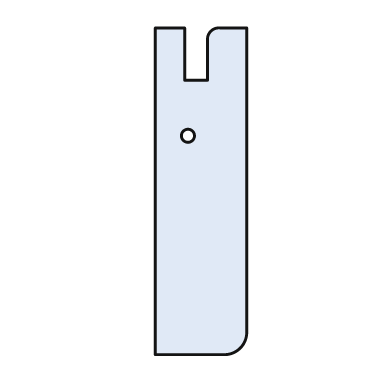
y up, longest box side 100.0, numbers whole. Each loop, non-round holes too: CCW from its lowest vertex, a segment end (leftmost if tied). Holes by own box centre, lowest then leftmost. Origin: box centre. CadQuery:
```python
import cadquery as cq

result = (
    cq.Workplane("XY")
    .moveTo(-14.0, -50.0)
    .lineTo(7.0, -50.0)
    .threePointArc((12.0, -48.0), (14.0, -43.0))
    .lineTo(14.0, 50.0)
    .lineTo(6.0, 50.0)
    .threePointArc((3.0, 49.0), (2.0, 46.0))
    .lineTo(2.0, 34.0)
    .lineTo(-5.0, 34.0)
    .lineTo(-5.0, 50.0)
    .lineTo(-14.0, 50.0)
    .close()
    .moveTo(-4.0, 17.0)
    .circle(2.0)
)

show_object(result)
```